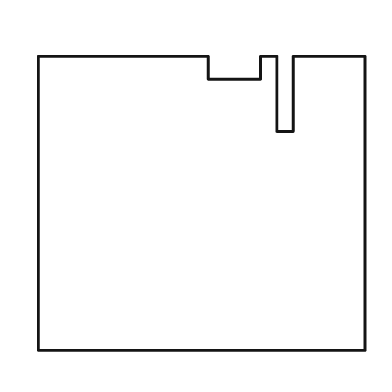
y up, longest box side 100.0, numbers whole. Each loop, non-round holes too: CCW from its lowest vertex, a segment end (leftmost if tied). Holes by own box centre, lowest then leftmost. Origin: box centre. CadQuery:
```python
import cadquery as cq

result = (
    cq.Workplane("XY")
    .moveTo(-50.0, -45.0)
    .lineTo(50.0, -45.0)
    .lineTo(50.0, 45.0)
    .lineTo(28.0, 45.0)
    .lineTo(28.0, 22.0)
    .lineTo(23.0, 22.0)
    .lineTo(23.0, 45.0)
    .lineTo(18.0, 45.0)
    .lineTo(18.0, 38.0)
    .lineTo(2.0, 38.0)
    .lineTo(2.0, 45.0)
    .lineTo(-50.0, 45.0)
    .close()
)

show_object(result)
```